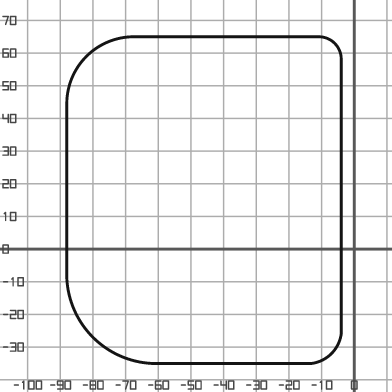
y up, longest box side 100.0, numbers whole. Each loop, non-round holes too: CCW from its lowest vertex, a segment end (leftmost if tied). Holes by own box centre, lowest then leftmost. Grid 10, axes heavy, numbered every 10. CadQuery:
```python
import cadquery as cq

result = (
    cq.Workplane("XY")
    .moveTo(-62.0, -35.0)
    .lineTo(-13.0, -35.0)
    .threePointArc((-7.0, -32.0), (-4.0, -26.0))
    .lineTo(-4.0, 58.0)
    .threePointArc((-6.0, 63.0), (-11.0, 65.0))
    .lineTo(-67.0, 65.0)
    .threePointArc((-82.0, 59.0), (-88.0, 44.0))
    .lineTo(-88.0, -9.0)
    .threePointArc((-80.0, -27.0), (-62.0, -35.0))
    .close()
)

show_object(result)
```